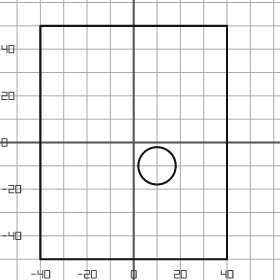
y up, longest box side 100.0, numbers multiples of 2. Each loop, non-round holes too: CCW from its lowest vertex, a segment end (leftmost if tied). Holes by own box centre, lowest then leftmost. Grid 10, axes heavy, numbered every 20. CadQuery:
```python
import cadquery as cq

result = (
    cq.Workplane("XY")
    .moveTo(-40.0, -50.0)
    .lineTo(40.0, -50.0)
    .lineTo(40.0, 50.0)
    .lineTo(-40.0, 50.0)
    .close()
    .moveTo(10.0, -10.0)
    .circle(8.0)
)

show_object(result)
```